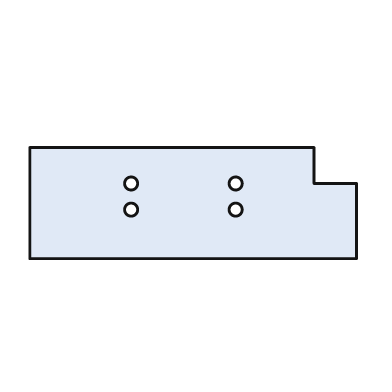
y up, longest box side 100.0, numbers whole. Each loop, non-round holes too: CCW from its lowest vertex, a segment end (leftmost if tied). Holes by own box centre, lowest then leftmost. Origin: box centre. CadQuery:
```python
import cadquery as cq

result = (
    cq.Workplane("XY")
    .moveTo(-50.0, -17.0)
    .lineTo(50.0, -17.0)
    .lineTo(50.0, 6.0)
    .lineTo(37.0, 6.0)
    .lineTo(37.0, 17.0)
    .lineTo(-50.0, 17.0)
    .close()
    .moveTo(-19.0, -2.0)
    .circle(2.0)
    .moveTo(13.0, -2.0)
    .circle(2.0)
    .moveTo(-19.0, 6.0)
    .circle(2.0)
    .moveTo(13.0, 6.0)
    .circle(2.0)
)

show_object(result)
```